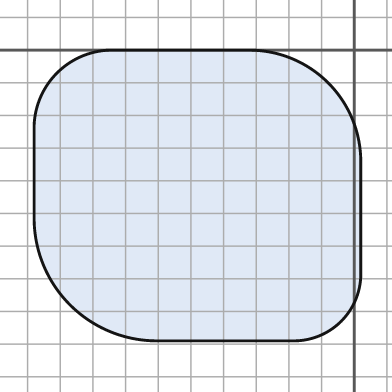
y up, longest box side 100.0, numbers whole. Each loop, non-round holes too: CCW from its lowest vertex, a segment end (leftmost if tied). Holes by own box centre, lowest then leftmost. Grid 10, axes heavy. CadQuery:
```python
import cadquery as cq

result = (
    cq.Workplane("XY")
    .moveTo(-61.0, -89.0)
    .lineTo(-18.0, -89.0)
    .threePointArc((-4.0, -83.0), (2.0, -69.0))
    .lineTo(2.0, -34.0)
    .threePointArc((-8.0, -10.0), (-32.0, 0.0))
    .lineTo(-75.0, 0.0)
    .threePointArc((-91.0, -7.0), (-98.0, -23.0))
    .lineTo(-98.0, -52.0)
    .threePointArc((-87.0, -78.0), (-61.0, -89.0))
    .close()
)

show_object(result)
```